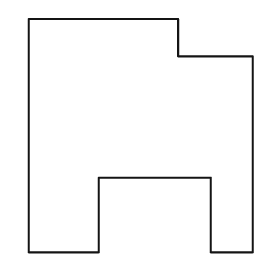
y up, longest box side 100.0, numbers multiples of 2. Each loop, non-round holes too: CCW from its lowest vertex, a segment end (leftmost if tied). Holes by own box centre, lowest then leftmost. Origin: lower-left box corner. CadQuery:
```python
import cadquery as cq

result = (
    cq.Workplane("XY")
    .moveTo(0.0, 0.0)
    .lineTo(30.0, 0.0)
    .lineTo(30.0, 32.0)
    .lineTo(78.0, 32.0)
    .lineTo(78.0, 0.0)
    .lineTo(96.0, 0.0)
    .lineTo(96.0, 84.0)
    .lineTo(64.0, 84.0)
    .lineTo(64.0, 100.0)
    .lineTo(0.0, 100.0)
    .close()
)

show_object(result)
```